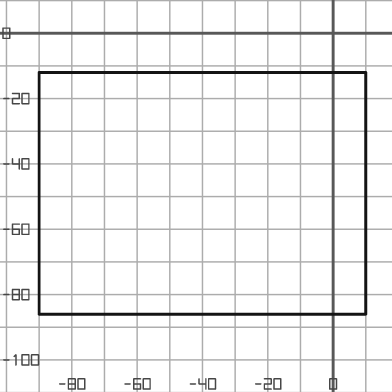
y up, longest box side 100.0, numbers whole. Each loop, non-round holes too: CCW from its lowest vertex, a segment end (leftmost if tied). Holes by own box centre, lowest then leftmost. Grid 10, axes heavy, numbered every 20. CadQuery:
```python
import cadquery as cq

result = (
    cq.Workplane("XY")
    .moveTo(-90.0, -86.0)
    .lineTo(10.0, -86.0)
    .lineTo(10.0, -12.0)
    .lineTo(-90.0, -12.0)
    .close()
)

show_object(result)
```